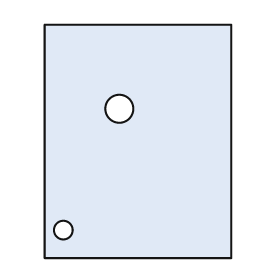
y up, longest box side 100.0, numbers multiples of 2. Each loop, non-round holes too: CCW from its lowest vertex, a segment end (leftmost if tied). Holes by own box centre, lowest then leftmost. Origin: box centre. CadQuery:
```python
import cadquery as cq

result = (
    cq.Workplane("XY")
    .moveTo(-40.0, -50.0)
    .lineTo(40.0, -50.0)
    .lineTo(40.0, 50.0)
    .lineTo(-40.0, 50.0)
    .close()
    .moveTo(-32.0, -38.0)
    .circle(4.0)
    .moveTo(-8.0, 14.0)
    .circle(6.0)
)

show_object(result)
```